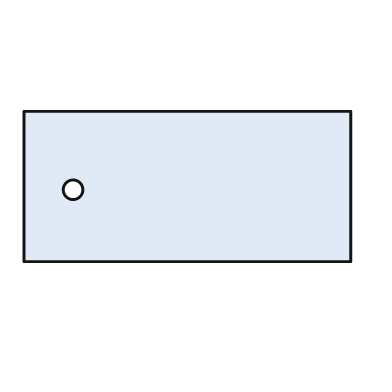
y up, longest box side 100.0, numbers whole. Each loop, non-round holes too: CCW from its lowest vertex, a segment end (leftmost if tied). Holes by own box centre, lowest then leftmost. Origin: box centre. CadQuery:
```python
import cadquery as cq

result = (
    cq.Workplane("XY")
    .moveTo(-50.0, -23.0)
    .lineTo(50.0, -23.0)
    .lineTo(50.0, 23.0)
    .lineTo(-50.0, 23.0)
    .close()
    .moveTo(-35.0, -1.0)
    .circle(3.0)
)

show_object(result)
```